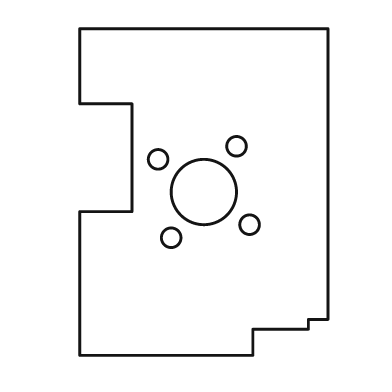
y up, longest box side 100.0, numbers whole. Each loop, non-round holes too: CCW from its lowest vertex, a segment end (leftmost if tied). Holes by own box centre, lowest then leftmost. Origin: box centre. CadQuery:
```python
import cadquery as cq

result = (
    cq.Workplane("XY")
    .moveTo(-38.0, -50.0)
    .lineTo(15.0, -50.0)
    .lineTo(15.0, -42.0)
    .lineTo(32.0, -42.0)
    .lineTo(32.0, -39.0)
    .lineTo(38.0, -39.0)
    .lineTo(38.0, 50.0)
    .lineTo(-38.0, 50.0)
    .lineTo(-38.0, 27.0)
    .lineTo(-22.0, 27.0)
    .lineTo(-22.0, -6.0)
    .lineTo(-38.0, -6.0)
    .close()
    .moveTo(-10.0, -14.0)
    .circle(3.0)
    .moveTo(14.0, -10.0)
    .circle(3.0)
    .moveTo(0.0, 0.0)
    .circle(10.0)
    .moveTo(-14.0, 10.0)
    .circle(3.0)
    .moveTo(10.0, 14.0)
    .circle(3.0)
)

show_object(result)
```